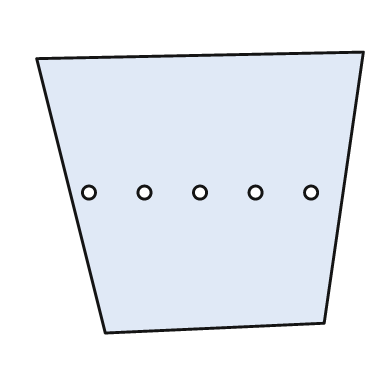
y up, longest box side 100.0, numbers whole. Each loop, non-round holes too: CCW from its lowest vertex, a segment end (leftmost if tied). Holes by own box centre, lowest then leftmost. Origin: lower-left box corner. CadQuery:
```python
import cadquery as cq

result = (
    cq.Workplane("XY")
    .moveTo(21.0, 0.0)
    .lineTo(88.0, 3.0)
    .lineTo(100.0, 86.0)
    .lineTo(0.0, 84.0)
    .close()
    .moveTo(16.0, 43.0)
    .circle(2.0)
    .moveTo(33.0, 43.0)
    .circle(2.0)
    .moveTo(50.0, 43.0)
    .circle(2.0)
    .moveTo(67.0, 43.0)
    .circle(2.0)
    .moveTo(84.0, 43.0)
    .circle(2.0)
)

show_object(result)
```